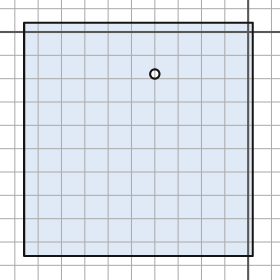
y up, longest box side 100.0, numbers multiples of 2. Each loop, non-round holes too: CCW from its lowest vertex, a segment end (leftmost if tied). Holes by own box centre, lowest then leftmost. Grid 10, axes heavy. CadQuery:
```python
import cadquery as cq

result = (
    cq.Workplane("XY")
    .moveTo(-96.0, -96.0)
    .lineTo(2.0, -96.0)
    .lineTo(2.0, 4.0)
    .lineTo(-96.0, 4.0)
    .close()
    .moveTo(-40.0, -18.0)
    .circle(2.0)
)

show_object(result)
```